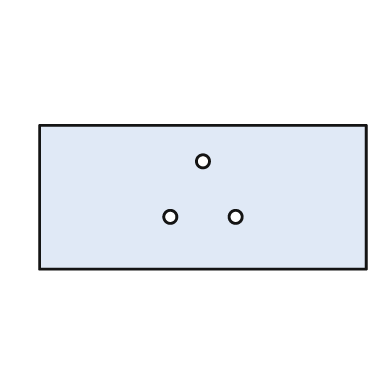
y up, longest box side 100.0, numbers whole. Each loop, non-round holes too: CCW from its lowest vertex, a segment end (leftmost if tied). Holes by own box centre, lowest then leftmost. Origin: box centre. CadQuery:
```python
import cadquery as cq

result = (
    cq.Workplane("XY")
    .moveTo(-50.0, -22.0)
    .lineTo(50.0, -22.0)
    .lineTo(50.0, 22.0)
    .lineTo(-50.0, 22.0)
    .close()
    .moveTo(-10.0, -6.0)
    .circle(2.0)
    .moveTo(10.0, -6.0)
    .circle(2.0)
    .moveTo(0.0, 11.0)
    .circle(2.0)
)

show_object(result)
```